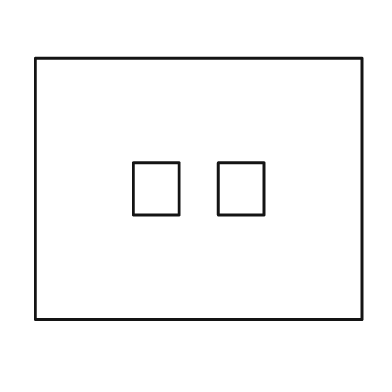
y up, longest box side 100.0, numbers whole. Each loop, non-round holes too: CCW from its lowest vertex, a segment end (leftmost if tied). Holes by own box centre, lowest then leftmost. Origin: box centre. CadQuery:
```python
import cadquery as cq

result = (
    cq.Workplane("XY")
    .moveTo(-50.0, -40.0)
    .lineTo(50.0, -40.0)
    .lineTo(50.0, 40.0)
    .lineTo(-50.0, 40.0)
    .close()
    .moveTo(-20.0, -8.0)
    .lineTo(-6.0, -8.0)
    .lineTo(-6.0, 8.0)
    .lineTo(-20.0, 8.0)
    .close()
    .moveTo(6.0, -8.0)
    .lineTo(20.0, -8.0)
    .lineTo(20.0, 8.0)
    .lineTo(6.0, 8.0)
    .close()
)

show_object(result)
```